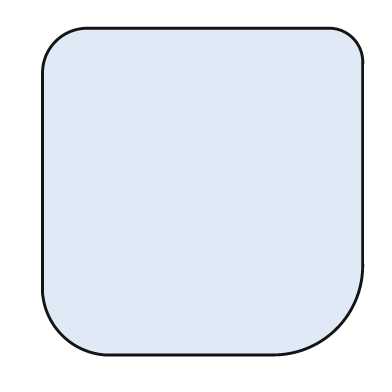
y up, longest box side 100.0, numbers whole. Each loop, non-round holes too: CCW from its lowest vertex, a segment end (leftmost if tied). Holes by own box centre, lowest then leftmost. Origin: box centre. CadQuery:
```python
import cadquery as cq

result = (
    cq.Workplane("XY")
    .moveTo(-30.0, -50.0)
    .lineTo(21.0, -50.0)
    .threePointArc((41.0, -42.0), (49.0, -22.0))
    .lineTo(49.0, 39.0)
    .threePointArc((46.0, 47.0), (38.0, 50.0))
    .lineTo(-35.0, 50.0)
    .threePointArc((-45.0, 46.0), (-49.0, 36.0))
    .lineTo(-49.0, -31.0)
    .threePointArc((-43.0, -44.0), (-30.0, -50.0))
    .close()
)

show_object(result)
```